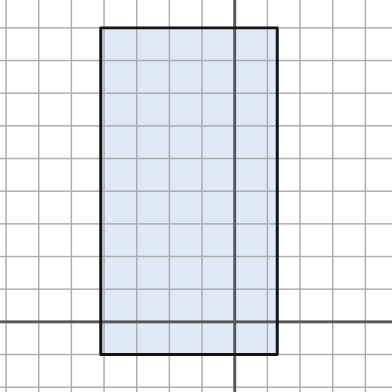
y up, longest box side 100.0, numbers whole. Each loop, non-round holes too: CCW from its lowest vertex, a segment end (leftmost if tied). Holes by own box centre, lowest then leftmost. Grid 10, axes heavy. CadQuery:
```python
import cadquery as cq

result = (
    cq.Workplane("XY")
    .moveTo(-41.0, -10.0)
    .lineTo(13.0, -10.0)
    .lineTo(13.0, 90.0)
    .lineTo(-41.0, 90.0)
    .close()
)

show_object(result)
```